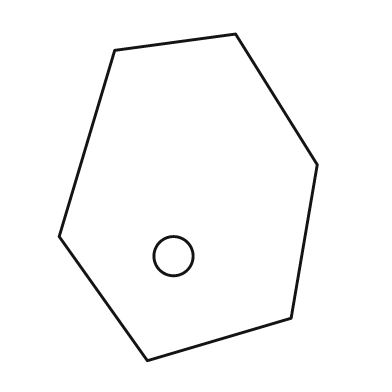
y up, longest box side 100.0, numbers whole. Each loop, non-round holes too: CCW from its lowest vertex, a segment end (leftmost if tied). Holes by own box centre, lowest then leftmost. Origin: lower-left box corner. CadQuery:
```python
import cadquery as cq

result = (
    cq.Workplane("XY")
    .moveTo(27.0, 0.0)
    .lineTo(71.0, 13.0)
    .lineTo(79.0, 60.0)
    .lineTo(54.0, 100.0)
    .lineTo(17.0, 95.0)
    .lineTo(0.0, 38.0)
    .close()
    .moveTo(35.0, 32.0)
    .circle(6.0)
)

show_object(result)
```